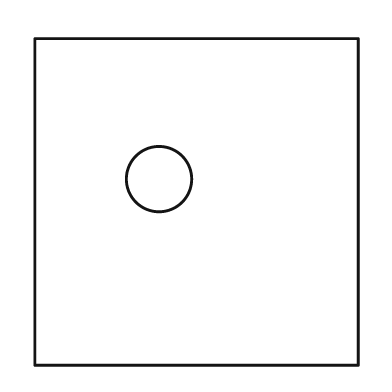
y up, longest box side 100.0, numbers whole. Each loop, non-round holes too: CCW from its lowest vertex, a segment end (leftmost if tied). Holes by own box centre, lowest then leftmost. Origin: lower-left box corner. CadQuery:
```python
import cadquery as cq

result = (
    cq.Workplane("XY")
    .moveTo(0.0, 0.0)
    .lineTo(99.0, 0.0)
    .lineTo(99.0, 100.0)
    .lineTo(0.0, 100.0)
    .close()
    .moveTo(38.0, 57.0)
    .circle(10.0)
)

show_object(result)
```